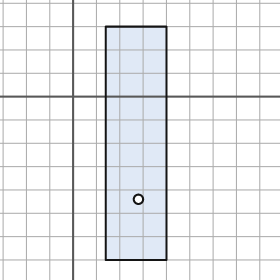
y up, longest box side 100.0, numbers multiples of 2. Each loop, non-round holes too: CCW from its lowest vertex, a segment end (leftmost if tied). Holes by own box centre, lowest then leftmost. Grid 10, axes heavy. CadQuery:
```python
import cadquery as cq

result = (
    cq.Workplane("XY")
    .moveTo(14.0, -70.0)
    .lineTo(40.0, -70.0)
    .lineTo(40.0, 30.0)
    .lineTo(14.0, 30.0)
    .close()
    .moveTo(28.0, -44.0)
    .circle(2.0)
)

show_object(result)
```